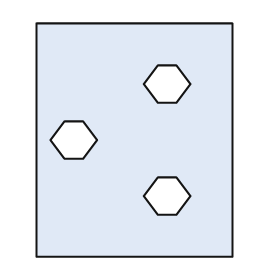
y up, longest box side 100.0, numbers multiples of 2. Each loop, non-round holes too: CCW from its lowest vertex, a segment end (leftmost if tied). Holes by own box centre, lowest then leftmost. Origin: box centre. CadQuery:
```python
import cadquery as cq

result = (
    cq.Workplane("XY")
    .moveTo(-42.0, -50.0)
    .lineTo(42.0, -50.0)
    .lineTo(42.0, 50.0)
    .lineTo(-42.0, 50.0)
    .close()
    .moveTo(10.0, -32.0)
    .lineTo(18.0, -32.0)
    .lineTo(24.0, -24.0)
    .lineTo(18.0, -16.0)
    .lineTo(10.0, -16.0)
    .lineTo(4.0, -24.0)
    .close()
    .moveTo(-30.0, -8.0)
    .lineTo(-22.0, -8.0)
    .lineTo(-16.0, 0.0)
    .lineTo(-22.0, 8.0)
    .lineTo(-30.0, 8.0)
    .lineTo(-36.0, 0.0)
    .close()
    .moveTo(10.0, 16.0)
    .lineTo(18.0, 16.0)
    .lineTo(24.0, 24.0)
    .lineTo(18.0, 32.0)
    .lineTo(10.0, 32.0)
    .lineTo(4.0, 24.0)
    .close()
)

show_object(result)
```